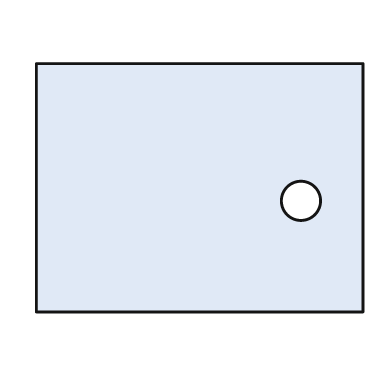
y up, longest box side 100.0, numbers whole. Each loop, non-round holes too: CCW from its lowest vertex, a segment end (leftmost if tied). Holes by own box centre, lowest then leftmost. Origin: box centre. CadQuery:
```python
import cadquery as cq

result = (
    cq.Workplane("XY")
    .moveTo(-50.0, -38.0)
    .lineTo(50.0, -38.0)
    .lineTo(50.0, 38.0)
    .lineTo(-50.0, 38.0)
    .close()
    .moveTo(31.0, -4.0)
    .circle(6.0)
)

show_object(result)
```